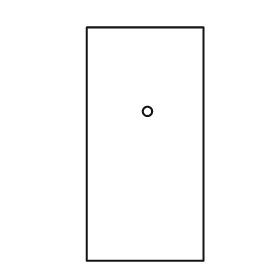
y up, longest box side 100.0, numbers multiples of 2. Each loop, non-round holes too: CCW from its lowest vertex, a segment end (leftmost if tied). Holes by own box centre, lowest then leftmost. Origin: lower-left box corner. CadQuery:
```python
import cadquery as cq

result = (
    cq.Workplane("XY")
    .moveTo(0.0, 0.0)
    .lineTo(50.0, 0.0)
    .lineTo(50.0, 100.0)
    .lineTo(0.0, 100.0)
    .close()
    .moveTo(26.0, 64.0)
    .circle(2.0)
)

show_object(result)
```